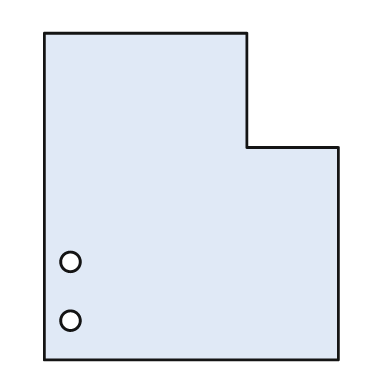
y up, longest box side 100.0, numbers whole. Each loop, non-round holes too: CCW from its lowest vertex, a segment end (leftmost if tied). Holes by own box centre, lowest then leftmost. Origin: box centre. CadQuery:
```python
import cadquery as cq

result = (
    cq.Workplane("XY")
    .moveTo(-45.0, -50.0)
    .lineTo(45.0, -50.0)
    .lineTo(45.0, 15.0)
    .lineTo(17.0, 15.0)
    .lineTo(17.0, 50.0)
    .lineTo(-45.0, 50.0)
    .close()
    .moveTo(-37.0, -38.0)
    .circle(3.0)
    .moveTo(-37.0, -20.0)
    .circle(3.0)
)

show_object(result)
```